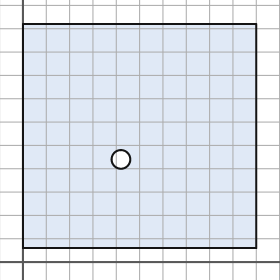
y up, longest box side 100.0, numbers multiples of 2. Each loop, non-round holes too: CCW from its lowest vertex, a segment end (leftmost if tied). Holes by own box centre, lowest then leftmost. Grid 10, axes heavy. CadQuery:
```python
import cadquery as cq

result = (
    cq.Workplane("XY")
    .moveTo(0.0, 6.0)
    .lineTo(100.0, 6.0)
    .lineTo(100.0, 102.0)
    .lineTo(0.0, 102.0)
    .close()
    .moveTo(42.0, 44.0)
    .circle(4.0)
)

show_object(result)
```